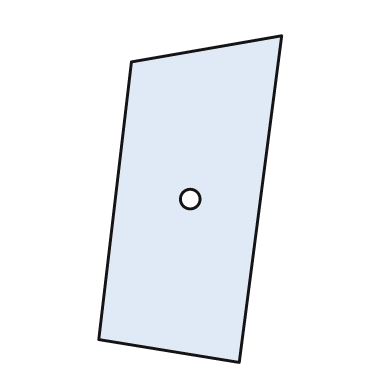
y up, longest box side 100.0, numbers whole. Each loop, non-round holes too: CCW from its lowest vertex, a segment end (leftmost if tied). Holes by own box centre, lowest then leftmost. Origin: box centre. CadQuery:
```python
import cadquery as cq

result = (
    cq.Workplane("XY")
    .moveTo(15.0, -50.0)
    .lineTo(28.0, 50.0)
    .lineTo(-18.0, 42.0)
    .lineTo(-28.0, -43.0)
    .close()
    .moveTo(0.0, 0.0)
    .circle(3.0)
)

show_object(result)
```